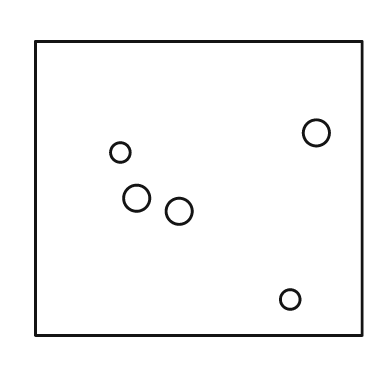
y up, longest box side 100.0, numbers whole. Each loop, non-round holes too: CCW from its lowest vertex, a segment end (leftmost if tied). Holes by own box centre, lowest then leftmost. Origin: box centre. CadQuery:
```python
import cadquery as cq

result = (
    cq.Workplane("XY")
    .moveTo(-50.0, -45.0)
    .lineTo(50.0, -45.0)
    .lineTo(50.0, 45.0)
    .lineTo(-50.0, 45.0)
    .close()
    .moveTo(28.0, -34.0)
    .circle(3.0)
    .moveTo(-6.0, -7.0)
    .circle(4.0)
    .moveTo(-19.0, -3.0)
    .circle(4.0)
    .moveTo(-24.0, 11.0)
    .circle(3.0)
    .moveTo(36.0, 17.0)
    .circle(4.0)
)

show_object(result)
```